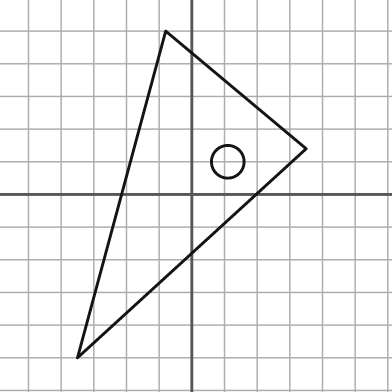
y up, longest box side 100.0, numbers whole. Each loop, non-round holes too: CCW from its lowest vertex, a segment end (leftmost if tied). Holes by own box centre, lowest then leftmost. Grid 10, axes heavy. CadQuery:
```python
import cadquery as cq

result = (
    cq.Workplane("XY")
    .moveTo(-35.0, -50.0)
    .lineTo(35.0, 14.0)
    .lineTo(-8.0, 50.0)
    .close()
    .moveTo(11.0, 10.0)
    .circle(5.0)
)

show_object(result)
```